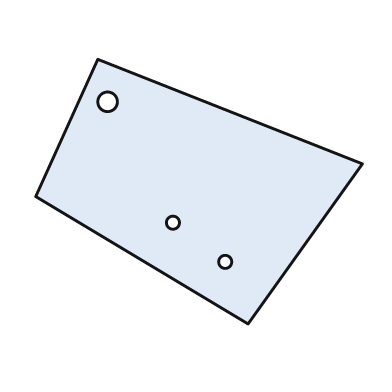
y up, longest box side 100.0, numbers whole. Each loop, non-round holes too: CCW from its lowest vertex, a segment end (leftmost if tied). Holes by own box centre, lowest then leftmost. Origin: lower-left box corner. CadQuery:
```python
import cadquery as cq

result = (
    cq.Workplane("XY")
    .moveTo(65.0, 0.0)
    .lineTo(100.0, 49.0)
    .lineTo(19.0, 81.0)
    .lineTo(0.0, 39.0)
    .close()
    .moveTo(58.0, 19.0)
    .circle(2.0)
    .moveTo(42.0, 31.0)
    .circle(2.0)
    .moveTo(22.0, 68.0)
    .circle(3.0)
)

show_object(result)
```